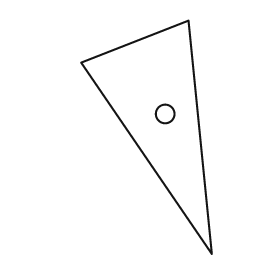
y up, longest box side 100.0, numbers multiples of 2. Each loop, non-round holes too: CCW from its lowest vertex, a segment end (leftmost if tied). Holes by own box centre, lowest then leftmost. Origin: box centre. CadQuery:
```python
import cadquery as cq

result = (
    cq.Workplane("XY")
    .moveTo(28.0, -50.0)
    .lineTo(18.0, 50.0)
    .lineTo(-28.0, 32.0)
    .close()
    .moveTo(8.0, 10.0)
    .circle(4.0)
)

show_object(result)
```